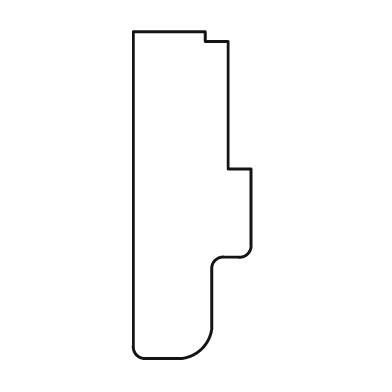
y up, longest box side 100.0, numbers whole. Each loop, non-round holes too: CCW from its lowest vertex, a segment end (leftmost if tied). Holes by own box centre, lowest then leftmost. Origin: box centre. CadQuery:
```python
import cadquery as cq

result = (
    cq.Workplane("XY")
    .moveTo(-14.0, -50.0)
    .lineTo(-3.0, -50.0)
    .threePointArc((3.0, -47.0), (6.0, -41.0))
    .lineTo(6.0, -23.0)
    .threePointArc((7.0, -20.0), (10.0, -19.0))
    .lineTo(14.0, -19.0)
    .threePointArc((17.0, -18.0), (18.0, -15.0))
    .lineTo(18.0, 8.0)
    .lineTo(11.0, 8.0)
    .lineTo(11.0, 47.0)
    .lineTo(4.0, 47.0)
    .lineTo(4.0, 50.0)
    .lineTo(-18.0, 50.0)
    .lineTo(-18.0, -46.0)
    .threePointArc((-17.0, -49.0), (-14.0, -50.0))
    .close()
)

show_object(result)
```